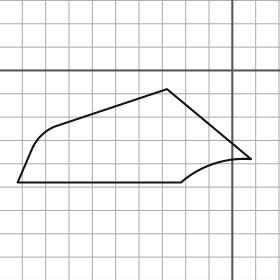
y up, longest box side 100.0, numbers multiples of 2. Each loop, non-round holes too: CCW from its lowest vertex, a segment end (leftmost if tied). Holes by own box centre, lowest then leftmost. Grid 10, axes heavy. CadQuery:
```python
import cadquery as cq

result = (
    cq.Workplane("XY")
    .moveTo(-92.0, -48.0)
    .lineTo(-22.0, -48.0)
    .threePointArc((-8.0, -40.0), (8.0, -38.0))
    .lineTo(-28.0, -8.0)
    .lineTo(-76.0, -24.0)
    .threePointArc((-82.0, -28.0), (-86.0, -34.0))
    .close()
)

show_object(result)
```